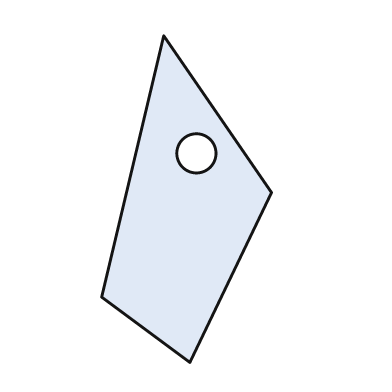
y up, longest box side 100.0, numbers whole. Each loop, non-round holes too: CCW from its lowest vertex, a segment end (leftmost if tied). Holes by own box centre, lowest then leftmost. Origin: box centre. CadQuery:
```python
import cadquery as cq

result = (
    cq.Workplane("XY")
    .moveTo(1.0, -50.0)
    .lineTo(26.0, 2.0)
    .lineTo(-7.0, 50.0)
    .lineTo(-26.0, -30.0)
    .close()
    .moveTo(3.0, 14.0)
    .circle(6.0)
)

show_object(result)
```